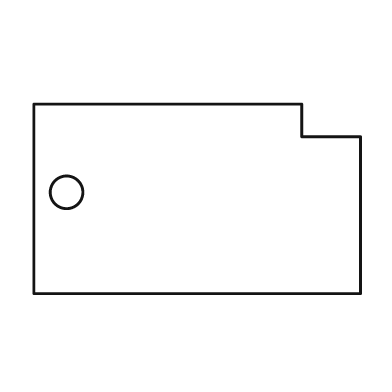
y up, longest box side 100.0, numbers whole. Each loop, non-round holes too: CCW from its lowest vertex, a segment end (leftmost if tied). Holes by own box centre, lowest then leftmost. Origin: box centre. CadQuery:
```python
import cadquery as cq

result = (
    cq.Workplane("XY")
    .moveTo(-50.0, -29.0)
    .lineTo(50.0, -29.0)
    .lineTo(50.0, 19.0)
    .lineTo(32.0, 19.0)
    .lineTo(32.0, 29.0)
    .lineTo(-50.0, 29.0)
    .close()
    .moveTo(-40.0, 2.0)
    .circle(5.0)
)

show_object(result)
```